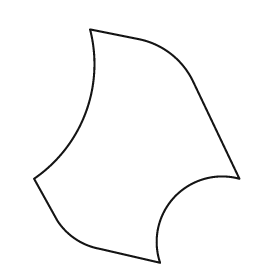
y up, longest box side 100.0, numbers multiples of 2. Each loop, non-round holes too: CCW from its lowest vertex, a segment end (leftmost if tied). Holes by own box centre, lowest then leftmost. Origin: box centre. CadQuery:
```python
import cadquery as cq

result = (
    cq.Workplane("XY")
    .moveTo(10.0, -50.0)
    .threePointArc((16.0, -22.0), (44.0, -14.0))
    .lineTo(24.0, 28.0)
    .threePointArc((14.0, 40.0), (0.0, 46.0))
    .lineTo(-20.0, 50.0)
    .threePointArc((-22.0, 14.0), (-44.0, -14.0))
    .lineTo(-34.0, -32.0)
    .threePointArc((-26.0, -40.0), (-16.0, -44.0))
    .close()
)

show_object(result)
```